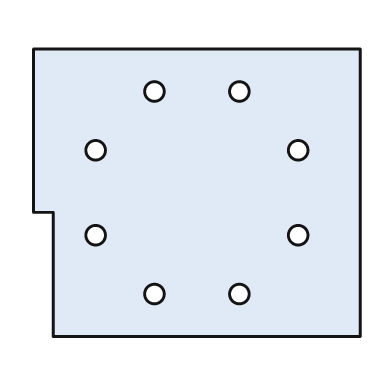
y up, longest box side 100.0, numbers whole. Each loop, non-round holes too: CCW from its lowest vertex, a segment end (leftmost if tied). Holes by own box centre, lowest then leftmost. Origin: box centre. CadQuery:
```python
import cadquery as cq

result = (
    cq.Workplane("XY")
    .moveTo(-44.0, -44.0)
    .lineTo(50.0, -44.0)
    .lineTo(50.0, 44.0)
    .lineTo(-50.0, 44.0)
    .lineTo(-50.0, -6.0)
    .lineTo(-44.0, -6.0)
    .close()
    .moveTo(-13.0, -31.0)
    .circle(3.0)
    .moveTo(13.0, -31.0)
    .circle(3.0)
    .moveTo(-31.0, -13.0)
    .circle(3.0)
    .moveTo(31.0, -13.0)
    .circle(3.0)
    .moveTo(-31.0, 13.0)
    .circle(3.0)
    .moveTo(31.0, 13.0)
    .circle(3.0)
    .moveTo(-13.0, 31.0)
    .circle(3.0)
    .moveTo(13.0, 31.0)
    .circle(3.0)
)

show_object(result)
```